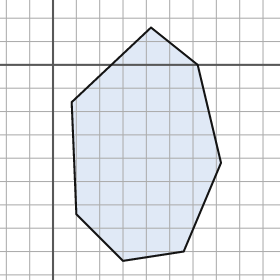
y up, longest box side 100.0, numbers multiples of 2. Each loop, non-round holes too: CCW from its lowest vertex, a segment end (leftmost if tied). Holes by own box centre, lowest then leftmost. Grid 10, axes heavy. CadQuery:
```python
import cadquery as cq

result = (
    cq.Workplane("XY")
    .moveTo(30.0, -84.0)
    .lineTo(56.0, -80.0)
    .lineTo(72.0, -42.0)
    .lineTo(62.0, 0.0)
    .lineTo(42.0, 16.0)
    .lineTo(8.0, -16.0)
    .lineTo(10.0, -64.0)
    .close()
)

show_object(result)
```